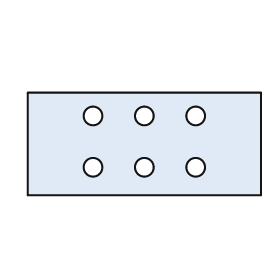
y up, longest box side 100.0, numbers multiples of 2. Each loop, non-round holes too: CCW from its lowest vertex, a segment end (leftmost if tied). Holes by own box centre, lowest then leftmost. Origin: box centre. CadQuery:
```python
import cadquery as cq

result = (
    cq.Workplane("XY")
    .moveTo(-50.0, -22.0)
    .lineTo(50.0, -22.0)
    .lineTo(50.0, 22.0)
    .lineTo(-50.0, 22.0)
    .close()
    .moveTo(-22.0, -10.0)
    .circle(4.0)
    .moveTo(0.0, -10.0)
    .circle(4.0)
    .moveTo(22.0, -10.0)
    .circle(4.0)
    .moveTo(-22.0, 12.0)
    .circle(4.0)
    .moveTo(0.0, 12.0)
    .circle(4.0)
    .moveTo(22.0, 12.0)
    .circle(4.0)
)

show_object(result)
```